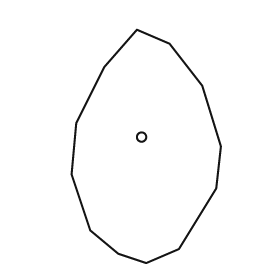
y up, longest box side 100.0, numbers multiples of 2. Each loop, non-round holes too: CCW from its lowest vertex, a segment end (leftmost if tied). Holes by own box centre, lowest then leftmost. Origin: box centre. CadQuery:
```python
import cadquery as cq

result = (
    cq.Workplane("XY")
    .moveTo(0.0, -50.0)
    .lineTo(14.0, -44.0)
    .lineTo(30.0, -18.0)
    .lineTo(32.0, 0.0)
    .lineTo(24.0, 26.0)
    .lineTo(10.0, 44.0)
    .lineTo(-4.0, 50.0)
    .lineTo(-18.0, 34.0)
    .lineTo(-30.0, 10.0)
    .lineTo(-32.0, -12.0)
    .lineTo(-24.0, -36.0)
    .lineTo(-12.0, -46.0)
    .close()
    .moveTo(-2.0, 4.0)
    .circle(2.0)
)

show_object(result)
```